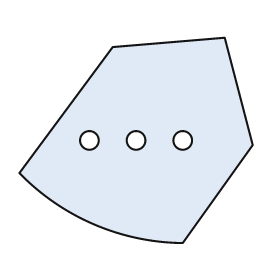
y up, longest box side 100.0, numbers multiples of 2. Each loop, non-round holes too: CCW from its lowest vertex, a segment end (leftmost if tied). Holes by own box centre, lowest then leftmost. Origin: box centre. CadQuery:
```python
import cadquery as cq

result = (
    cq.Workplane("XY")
    .moveTo(20.0, -44.0)
    .lineTo(50.0, -2.0)
    .lineTo(38.0, 44.0)
    .lineTo(-10.0, 40.0)
    .lineTo(-50.0, -14.0)
    .threePointArc((-18.0, -36.0), (20.0, -44.0))
    .close()
    .moveTo(-20.0, 0.0)
    .circle(4.0)
    .moveTo(0.0, 0.0)
    .circle(4.0)
    .moveTo(20.0, 0.0)
    .circle(4.0)
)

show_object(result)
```